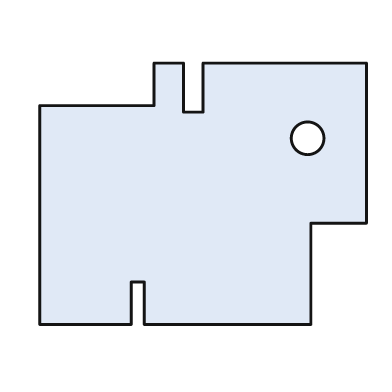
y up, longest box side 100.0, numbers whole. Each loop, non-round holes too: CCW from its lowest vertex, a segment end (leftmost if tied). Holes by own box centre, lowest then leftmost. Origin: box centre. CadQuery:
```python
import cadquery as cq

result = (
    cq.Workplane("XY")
    .moveTo(-50.0, -40.0)
    .lineTo(-22.0, -40.0)
    .lineTo(-22.0, -27.0)
    .lineTo(-18.0, -27.0)
    .lineTo(-18.0, -40.0)
    .lineTo(33.0, -40.0)
    .lineTo(33.0, -9.0)
    .lineTo(50.0, -9.0)
    .lineTo(50.0, 40.0)
    .lineTo(0.0, 40.0)
    .lineTo(0.0, 25.0)
    .lineTo(-6.0, 25.0)
    .lineTo(-6.0, 40.0)
    .lineTo(-15.0, 40.0)
    .lineTo(-15.0, 27.0)
    .lineTo(-50.0, 27.0)
    .close()
    .moveTo(32.0, 17.0)
    .circle(5.0)
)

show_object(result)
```